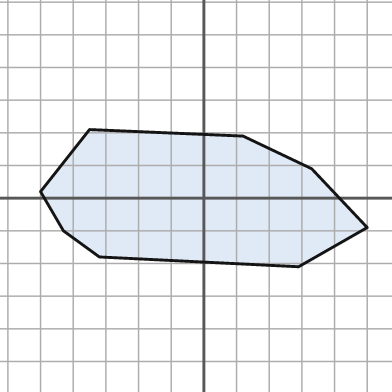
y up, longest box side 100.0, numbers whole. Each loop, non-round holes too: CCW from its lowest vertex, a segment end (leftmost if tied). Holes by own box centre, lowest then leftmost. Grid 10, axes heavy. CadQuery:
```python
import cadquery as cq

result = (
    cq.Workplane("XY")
    .moveTo(29.0, -21.0)
    .lineTo(50.0, -9.0)
    .lineTo(33.0, 9.0)
    .lineTo(12.0, 19.0)
    .lineTo(-35.0, 21.0)
    .lineTo(-50.0, 2.0)
    .lineTo(-43.0, -10.0)
    .lineTo(-32.0, -18.0)
    .close()
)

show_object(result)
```